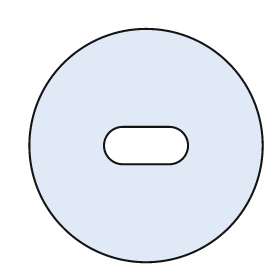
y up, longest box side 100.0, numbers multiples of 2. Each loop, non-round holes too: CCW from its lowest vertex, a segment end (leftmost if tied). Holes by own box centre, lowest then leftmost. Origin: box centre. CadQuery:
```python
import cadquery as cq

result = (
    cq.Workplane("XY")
    .moveTo(0.0, 0.0)
    .circle(50.0)
    .moveTo(-10.0, -8.0)
    .lineTo(10.0, -8.0)
    .threePointArc((18.0, 0.0), (10.0, 8.0))
    .lineTo(-10.0, 8.0)
    .threePointArc((-18.0, 0.0), (-10.0, -8.0))
    .close()
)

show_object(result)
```